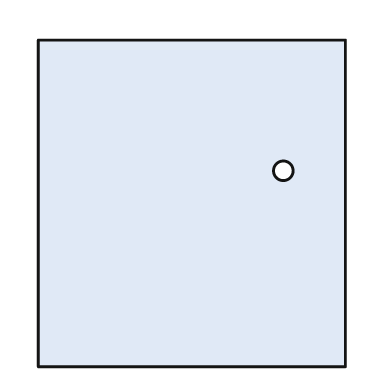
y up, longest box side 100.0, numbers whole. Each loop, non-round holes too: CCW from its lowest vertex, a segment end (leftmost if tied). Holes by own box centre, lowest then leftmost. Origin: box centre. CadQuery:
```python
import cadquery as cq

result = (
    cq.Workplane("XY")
    .moveTo(-47.0, -50.0)
    .lineTo(47.0, -50.0)
    .lineTo(47.0, 50.0)
    .lineTo(-47.0, 50.0)
    .close()
    .moveTo(28.0, 10.0)
    .circle(3.0)
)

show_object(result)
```